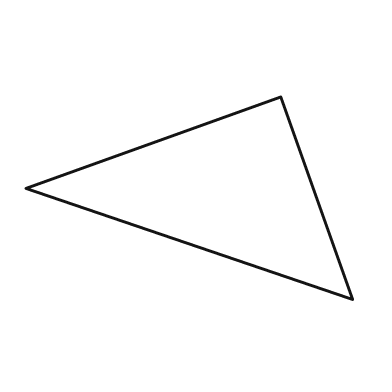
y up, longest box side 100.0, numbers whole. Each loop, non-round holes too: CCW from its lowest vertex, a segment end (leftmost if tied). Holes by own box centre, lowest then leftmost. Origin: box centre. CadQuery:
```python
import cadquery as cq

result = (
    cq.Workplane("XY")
    .moveTo(50.0, -31.0)
    .lineTo(28.0, 31.0)
    .lineTo(-50.0, 3.0)
    .close()
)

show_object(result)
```